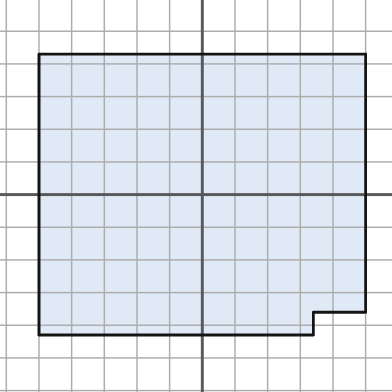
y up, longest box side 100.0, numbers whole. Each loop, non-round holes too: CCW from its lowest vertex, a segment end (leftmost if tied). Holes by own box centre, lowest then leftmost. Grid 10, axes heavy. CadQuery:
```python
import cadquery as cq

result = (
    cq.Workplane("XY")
    .moveTo(-50.0, -43.0)
    .lineTo(34.0, -43.0)
    .lineTo(34.0, -36.0)
    .lineTo(50.0, -36.0)
    .lineTo(50.0, 43.0)
    .lineTo(-50.0, 43.0)
    .close()
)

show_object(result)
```